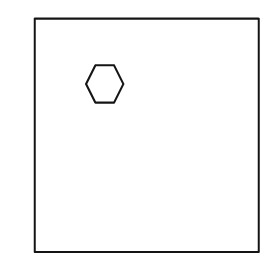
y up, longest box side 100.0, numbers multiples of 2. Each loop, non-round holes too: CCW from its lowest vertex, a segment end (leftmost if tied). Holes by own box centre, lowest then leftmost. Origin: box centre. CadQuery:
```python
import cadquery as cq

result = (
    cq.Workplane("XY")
    .moveTo(-48.0, -50.0)
    .lineTo(48.0, -50.0)
    .lineTo(48.0, 50.0)
    .lineTo(-48.0, 50.0)
    .close()
    .moveTo(-22.0, 14.0)
    .lineTo(-14.0, 14.0)
    .lineTo(-10.0, 22.0)
    .lineTo(-14.0, 30.0)
    .lineTo(-22.0, 30.0)
    .lineTo(-26.0, 22.0)
    .close()
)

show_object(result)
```